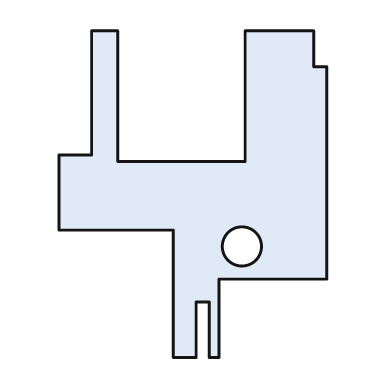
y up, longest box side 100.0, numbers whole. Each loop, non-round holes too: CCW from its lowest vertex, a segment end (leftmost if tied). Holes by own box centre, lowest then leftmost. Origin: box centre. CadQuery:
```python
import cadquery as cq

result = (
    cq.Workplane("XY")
    .moveTo(-6.0, -50.0)
    .lineTo(1.0, -50.0)
    .lineTo(1.0, -33.0)
    .lineTo(5.0, -33.0)
    .lineTo(5.0, -50.0)
    .lineTo(8.0, -50.0)
    .lineTo(8.0, -26.0)
    .lineTo(41.0, -26.0)
    .lineTo(41.0, 39.0)
    .lineTo(37.0, 39.0)
    .lineTo(37.0, 50.0)
    .lineTo(16.0, 50.0)
    .lineTo(16.0, 10.0)
    .lineTo(-23.0, 10.0)
    .lineTo(-23.0, 50.0)
    .lineTo(-31.0, 50.0)
    .lineTo(-31.0, 12.0)
    .lineTo(-41.0, 12.0)
    .lineTo(-41.0, -11.0)
    .lineTo(-6.0, -11.0)
    .close()
    .moveTo(15.0, -16.0)
    .circle(6.0)
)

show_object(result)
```